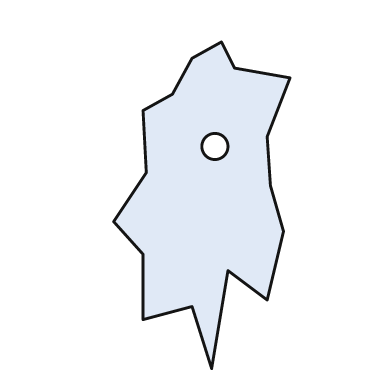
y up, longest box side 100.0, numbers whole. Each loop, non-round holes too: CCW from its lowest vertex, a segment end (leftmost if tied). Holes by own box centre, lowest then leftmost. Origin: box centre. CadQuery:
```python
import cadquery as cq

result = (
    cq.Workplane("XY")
    .moveTo(3.0, -50.0)
    .lineTo(8.0, -20.0)
    .lineTo(20.0, -29.0)
    .lineTo(25.0, -8.0)
    .lineTo(21.0, 6.0)
    .lineTo(20.0, 21.0)
    .lineTo(27.0, 39.0)
    .lineTo(10.0, 42.0)
    .lineTo(6.0, 50.0)
    .lineTo(-3.0, 45.0)
    .lineTo(-9.0, 34.0)
    .lineTo(-18.0, 29.0)
    .lineTo(-17.0, 10.0)
    .lineTo(-27.0, -5.0)
    .lineTo(-18.0, -15.0)
    .lineTo(-18.0, -35.0)
    .lineTo(-3.0, -31.0)
    .close()
    .moveTo(4.0, 18.0)
    .circle(4.0)
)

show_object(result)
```